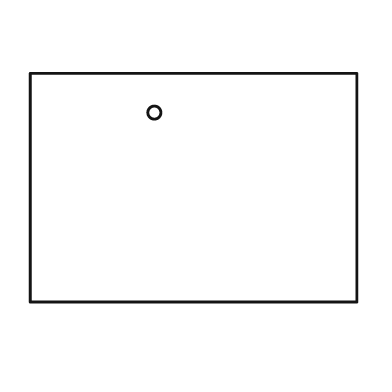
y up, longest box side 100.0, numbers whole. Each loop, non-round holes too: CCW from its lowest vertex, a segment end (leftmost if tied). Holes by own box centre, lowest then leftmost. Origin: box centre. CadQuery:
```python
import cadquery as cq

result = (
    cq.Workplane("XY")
    .moveTo(-50.0, -35.0)
    .lineTo(50.0, -35.0)
    .lineTo(50.0, 35.0)
    .lineTo(-50.0, 35.0)
    .close()
    .moveTo(-12.0, 23.0)
    .circle(2.0)
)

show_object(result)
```